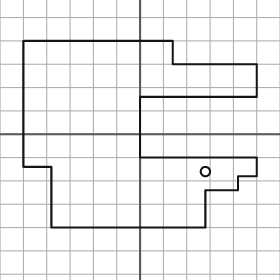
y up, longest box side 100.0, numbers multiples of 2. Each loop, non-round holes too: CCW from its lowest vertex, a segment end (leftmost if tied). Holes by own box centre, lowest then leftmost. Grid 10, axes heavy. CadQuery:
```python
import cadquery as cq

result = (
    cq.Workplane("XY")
    .moveTo(-38.0, -40.0)
    .lineTo(28.0, -40.0)
    .lineTo(28.0, -24.0)
    .lineTo(42.0, -24.0)
    .lineTo(42.0, -18.0)
    .lineTo(50.0, -18.0)
    .lineTo(50.0, -10.0)
    .lineTo(0.0, -10.0)
    .lineTo(0.0, 16.0)
    .lineTo(50.0, 16.0)
    .lineTo(50.0, 30.0)
    .lineTo(14.0, 30.0)
    .lineTo(14.0, 40.0)
    .lineTo(-50.0, 40.0)
    .lineTo(-50.0, -14.0)
    .lineTo(-38.0, -14.0)
    .close()
    .moveTo(28.0, -16.0)
    .circle(2.0)
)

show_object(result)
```